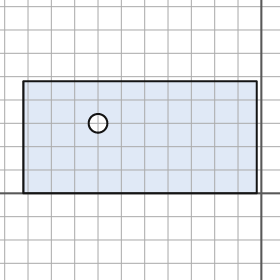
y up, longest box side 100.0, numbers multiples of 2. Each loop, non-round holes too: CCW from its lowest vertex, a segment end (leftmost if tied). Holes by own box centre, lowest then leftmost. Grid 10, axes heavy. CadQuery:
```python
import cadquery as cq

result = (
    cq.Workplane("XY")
    .moveTo(-102.0, 0.0)
    .lineTo(-2.0, 0.0)
    .lineTo(-2.0, 48.0)
    .lineTo(-102.0, 48.0)
    .close()
    .moveTo(-70.0, 30.0)
    .circle(4.0)
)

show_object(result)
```